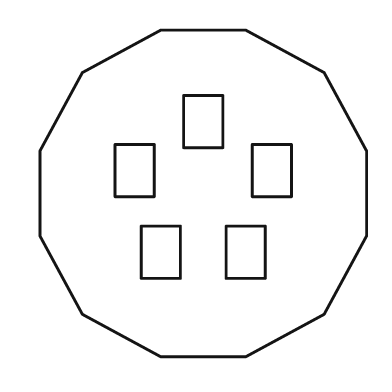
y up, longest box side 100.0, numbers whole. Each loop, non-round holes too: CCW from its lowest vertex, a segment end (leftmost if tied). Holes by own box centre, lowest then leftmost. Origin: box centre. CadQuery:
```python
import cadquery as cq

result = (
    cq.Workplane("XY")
    .moveTo(-13.0, -50.0)
    .lineTo(13.0, -50.0)
    .lineTo(37.0, -37.0)
    .lineTo(50.0, -13.0)
    .lineTo(50.0, 13.0)
    .lineTo(37.0, 37.0)
    .lineTo(13.0, 50.0)
    .lineTo(-13.0, 50.0)
    .lineTo(-37.0, 37.0)
    .lineTo(-50.0, 13.0)
    .lineTo(-50.0, -13.0)
    .lineTo(-37.0, -37.0)
    .close()
    .moveTo(-19.0, -26.0)
    .lineTo(-7.0, -26.0)
    .lineTo(-7.0, -10.0)
    .lineTo(-19.0, -10.0)
    .close()
    .moveTo(7.0, -26.0)
    .lineTo(19.0, -26.0)
    .lineTo(19.0, -10.0)
    .lineTo(7.0, -10.0)
    .close()
    .moveTo(-27.0, -1.0)
    .lineTo(-15.0, -1.0)
    .lineTo(-15.0, 15.0)
    .lineTo(-27.0, 15.0)
    .close()
    .moveTo(15.0, -1.0)
    .lineTo(27.0, -1.0)
    .lineTo(27.0, 15.0)
    .lineTo(15.0, 15.0)
    .close()
    .moveTo(-6.0, 14.0)
    .lineTo(6.0, 14.0)
    .lineTo(6.0, 30.0)
    .lineTo(-6.0, 30.0)
    .close()
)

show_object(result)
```